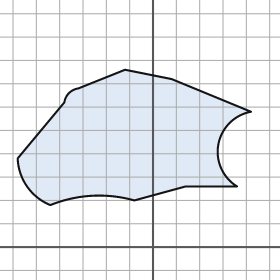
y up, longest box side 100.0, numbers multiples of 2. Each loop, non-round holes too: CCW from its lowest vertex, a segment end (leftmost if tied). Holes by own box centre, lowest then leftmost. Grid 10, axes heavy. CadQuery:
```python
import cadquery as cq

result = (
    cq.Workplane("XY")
    .moveTo(-44.0, 18.0)
    .threePointArc((-26.0, 22.0), (-8.0, 20.0))
    .lineTo(14.0, 26.0)
    .lineTo(36.0, 26.0)
    .threePointArc((28.0, 44.0), (42.0, 58.0))
    .lineTo(8.0, 72.0)
    .lineTo(-12.0, 76.0)
    .lineTo(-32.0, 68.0)
    .threePointArc((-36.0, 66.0), (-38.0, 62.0))
    .lineTo(-58.0, 38.0)
    .threePointArc((-54.0, 26.0), (-44.0, 18.0))
    .close()
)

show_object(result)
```